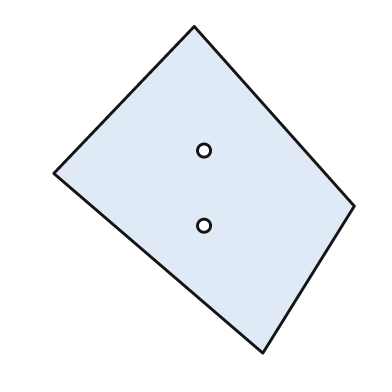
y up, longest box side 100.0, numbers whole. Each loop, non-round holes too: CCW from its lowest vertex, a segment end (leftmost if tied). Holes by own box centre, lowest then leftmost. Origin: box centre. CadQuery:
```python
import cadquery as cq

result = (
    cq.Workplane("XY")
    .moveTo(18.0, -50.0)
    .lineTo(46.0, -5.0)
    .lineTo(-3.0, 50.0)
    .lineTo(-46.0, 5.0)
    .close()
    .moveTo(0.0, -11.0)
    .circle(2.0)
    .moveTo(0.0, 12.0)
    .circle(2.0)
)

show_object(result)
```